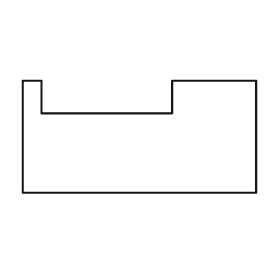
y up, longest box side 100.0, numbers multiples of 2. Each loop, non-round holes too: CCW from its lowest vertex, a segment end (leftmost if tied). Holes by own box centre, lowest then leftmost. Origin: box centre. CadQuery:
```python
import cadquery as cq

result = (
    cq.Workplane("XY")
    .moveTo(-50.0, -24.0)
    .lineTo(50.0, -24.0)
    .lineTo(50.0, 24.0)
    .lineTo(14.0, 24.0)
    .lineTo(14.0, 10.0)
    .lineTo(-42.0, 10.0)
    .lineTo(-42.0, 24.0)
    .lineTo(-50.0, 24.0)
    .close()
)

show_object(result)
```